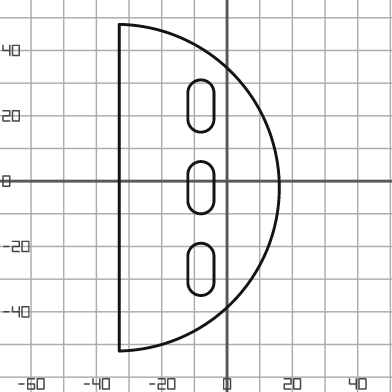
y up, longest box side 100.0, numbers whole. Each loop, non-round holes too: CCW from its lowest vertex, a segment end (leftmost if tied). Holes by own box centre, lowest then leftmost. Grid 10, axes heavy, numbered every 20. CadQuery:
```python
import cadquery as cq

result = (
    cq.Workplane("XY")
    .moveTo(-33.0, -52.0)
    .threePointArc((16.0, -2.0), (-33.0, 48.0))
    .close()
    .moveTo(-12.0, -31.0)
    .threePointArc((-8.0, -35.0), (-4.0, -31.0))
    .lineTo(-4.0, -23.0)
    .threePointArc((-8.0, -19.0), (-12.0, -23.0))
    .close()
    .moveTo(-12.0, -6.0)
    .threePointArc((-8.0, -10.0), (-4.0, -6.0))
    .lineTo(-4.0, 2.0)
    .threePointArc((-8.0, 6.0), (-12.0, 2.0))
    .close()
    .moveTo(-12.0, 19.0)
    .threePointArc((-8.0, 15.0), (-4.0, 19.0))
    .lineTo(-4.0, 27.0)
    .threePointArc((-8.0, 31.0), (-12.0, 27.0))
    .close()
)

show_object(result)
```